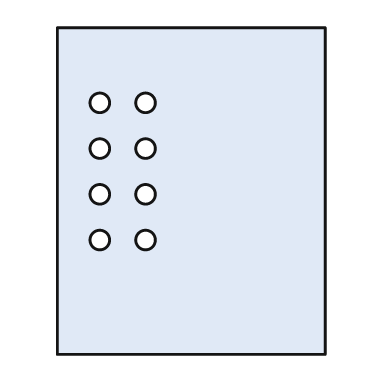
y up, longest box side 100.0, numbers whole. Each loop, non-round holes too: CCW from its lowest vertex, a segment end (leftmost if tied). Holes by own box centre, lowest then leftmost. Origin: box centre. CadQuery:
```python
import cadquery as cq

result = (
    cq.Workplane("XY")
    .moveTo(-41.0, -50.0)
    .lineTo(41.0, -50.0)
    .lineTo(41.0, 50.0)
    .lineTo(-41.0, 50.0)
    .close()
    .moveTo(-28.0, -15.0)
    .circle(3.0)
    .moveTo(-14.0, -15.0)
    .circle(3.0)
    .moveTo(-28.0, -1.0)
    .circle(3.0)
    .moveTo(-14.0, -1.0)
    .circle(3.0)
    .moveTo(-28.0, 13.0)
    .circle(3.0)
    .moveTo(-14.0, 13.0)
    .circle(3.0)
    .moveTo(-28.0, 27.0)
    .circle(3.0)
    .moveTo(-14.0, 27.0)
    .circle(3.0)
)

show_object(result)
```